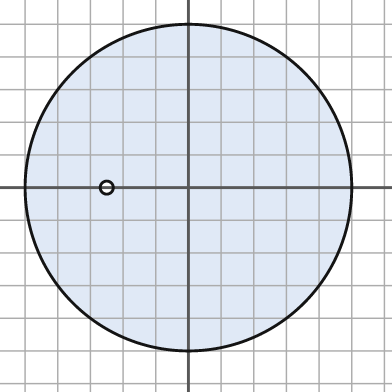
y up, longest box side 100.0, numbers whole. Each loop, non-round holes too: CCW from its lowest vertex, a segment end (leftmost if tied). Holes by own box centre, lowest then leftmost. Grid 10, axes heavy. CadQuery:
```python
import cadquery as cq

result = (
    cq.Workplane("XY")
    .moveTo(0.0, 0.0)
    .circle(50.0)
    .moveTo(-25.0, 0.0)
    .circle(2.0)
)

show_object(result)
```